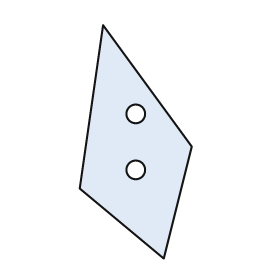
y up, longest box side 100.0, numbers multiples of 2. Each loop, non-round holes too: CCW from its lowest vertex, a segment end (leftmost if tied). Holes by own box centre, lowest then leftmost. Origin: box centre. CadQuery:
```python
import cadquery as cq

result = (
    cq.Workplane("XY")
    .moveTo(12.0, -50.0)
    .lineTo(24.0, -2.0)
    .lineTo(-14.0, 50.0)
    .lineTo(-24.0, -20.0)
    .close()
    .moveTo(0.0, -12.0)
    .circle(4.0)
    .moveTo(0.0, 12.0)
    .circle(4.0)
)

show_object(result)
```